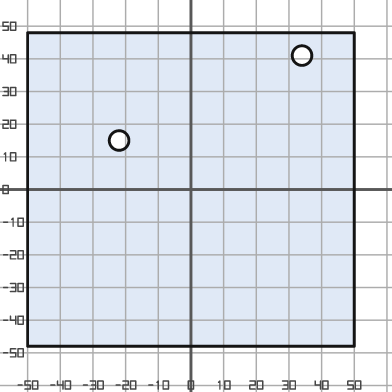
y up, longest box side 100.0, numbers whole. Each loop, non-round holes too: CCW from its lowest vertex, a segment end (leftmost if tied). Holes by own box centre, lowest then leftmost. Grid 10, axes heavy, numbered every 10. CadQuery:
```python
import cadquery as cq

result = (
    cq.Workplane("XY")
    .moveTo(-50.0, -48.0)
    .lineTo(50.0, -48.0)
    .lineTo(50.0, 48.0)
    .lineTo(-50.0, 48.0)
    .close()
    .moveTo(-22.0, 15.0)
    .circle(3.0)
    .moveTo(34.0, 41.0)
    .circle(3.0)
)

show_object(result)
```